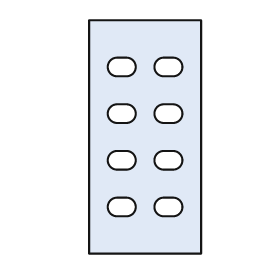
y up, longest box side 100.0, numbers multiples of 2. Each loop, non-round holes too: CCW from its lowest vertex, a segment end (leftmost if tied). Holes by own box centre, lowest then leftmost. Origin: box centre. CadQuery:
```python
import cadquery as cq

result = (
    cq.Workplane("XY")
    .moveTo(-24.0, -50.0)
    .lineTo(24.0, -50.0)
    .lineTo(24.0, 50.0)
    .lineTo(-24.0, 50.0)
    .close()
    .moveTo(-12.0, -34.0)
    .lineTo(-8.0, -34.0)
    .threePointArc((-4.0, -30.0), (-8.0, -26.0))
    .lineTo(-12.0, -26.0)
    .threePointArc((-16.0, -30.0), (-12.0, -34.0))
    .close()
    .moveTo(8.0, -34.0)
    .lineTo(12.0, -34.0)
    .threePointArc((16.0, -30.0), (12.0, -26.0))
    .lineTo(8.0, -26.0)
    .threePointArc((4.0, -30.0), (8.0, -34.0))
    .close()
    .moveTo(-12.0, -14.0)
    .lineTo(-8.0, -14.0)
    .threePointArc((-4.0, -10.0), (-8.0, -6.0))
    .lineTo(-12.0, -6.0)
    .threePointArc((-16.0, -10.0), (-12.0, -14.0))
    .close()
    .moveTo(8.0, -14.0)
    .lineTo(12.0, -14.0)
    .threePointArc((16.0, -10.0), (12.0, -6.0))
    .lineTo(8.0, -6.0)
    .threePointArc((4.0, -10.0), (8.0, -14.0))
    .close()
    .moveTo(-12.0, 6.0)
    .lineTo(-8.0, 6.0)
    .threePointArc((-4.0, 10.0), (-8.0, 14.0))
    .lineTo(-12.0, 14.0)
    .threePointArc((-16.0, 10.0), (-12.0, 6.0))
    .close()
    .moveTo(8.0, 6.0)
    .lineTo(12.0, 6.0)
    .threePointArc((16.0, 10.0), (12.0, 14.0))
    .lineTo(8.0, 14.0)
    .threePointArc((4.0, 10.0), (8.0, 6.0))
    .close()
    .moveTo(-12.0, 26.0)
    .lineTo(-8.0, 26.0)
    .threePointArc((-4.0, 30.0), (-8.0, 34.0))
    .lineTo(-12.0, 34.0)
    .threePointArc((-16.0, 30.0), (-12.0, 26.0))
    .close()
    .moveTo(8.0, 26.0)
    .lineTo(12.0, 26.0)
    .threePointArc((16.0, 30.0), (12.0, 34.0))
    .lineTo(8.0, 34.0)
    .threePointArc((4.0, 30.0), (8.0, 26.0))
    .close()
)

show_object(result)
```